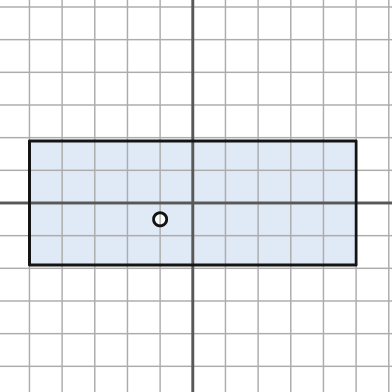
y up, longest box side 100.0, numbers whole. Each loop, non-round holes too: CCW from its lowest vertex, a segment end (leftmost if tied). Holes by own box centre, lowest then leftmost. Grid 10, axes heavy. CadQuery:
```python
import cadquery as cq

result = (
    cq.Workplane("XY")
    .moveTo(-50.0, -19.0)
    .lineTo(50.0, -19.0)
    .lineTo(50.0, 19.0)
    .lineTo(-50.0, 19.0)
    .close()
    .moveTo(-10.0, -5.0)
    .circle(2.0)
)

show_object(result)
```